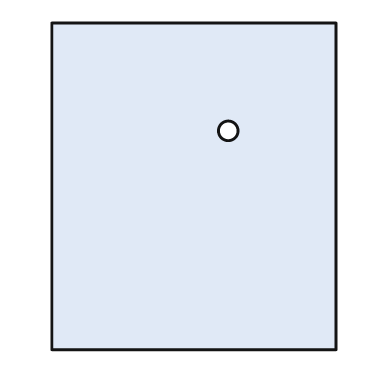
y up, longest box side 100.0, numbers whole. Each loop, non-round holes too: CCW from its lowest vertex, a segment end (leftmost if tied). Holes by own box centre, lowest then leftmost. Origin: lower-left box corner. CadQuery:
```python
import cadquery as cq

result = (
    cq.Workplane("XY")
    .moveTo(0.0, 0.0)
    .lineTo(87.0, 0.0)
    .lineTo(87.0, 100.0)
    .lineTo(0.0, 100.0)
    .close()
    .moveTo(54.0, 67.0)
    .circle(3.0)
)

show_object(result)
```